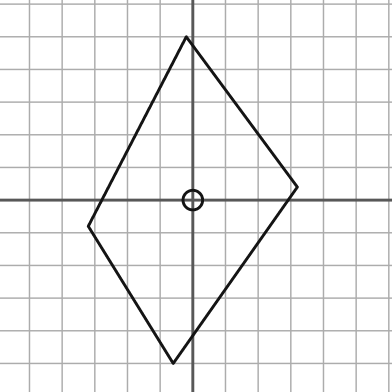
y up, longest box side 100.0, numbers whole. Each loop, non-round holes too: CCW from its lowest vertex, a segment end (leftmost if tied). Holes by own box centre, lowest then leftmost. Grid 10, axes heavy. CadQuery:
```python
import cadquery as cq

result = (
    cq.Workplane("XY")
    .moveTo(-6.0, -50.0)
    .lineTo(32.0, 4.0)
    .lineTo(-2.0, 50.0)
    .lineTo(-32.0, -8.0)
    .close()
    .moveTo(0.0, 0.0)
    .circle(3.0)
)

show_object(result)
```